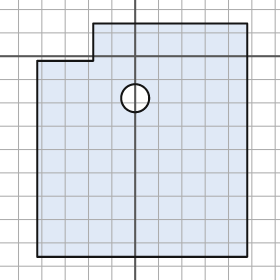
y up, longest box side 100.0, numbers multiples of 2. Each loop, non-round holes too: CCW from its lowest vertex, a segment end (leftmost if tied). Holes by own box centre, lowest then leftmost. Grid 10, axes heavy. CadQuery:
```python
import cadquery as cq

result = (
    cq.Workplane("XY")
    .moveTo(-42.0, -86.0)
    .lineTo(48.0, -86.0)
    .lineTo(48.0, 14.0)
    .lineTo(-18.0, 14.0)
    .lineTo(-18.0, -2.0)
    .lineTo(-42.0, -2.0)
    .close()
    .moveTo(0.0, -18.0)
    .circle(6.0)
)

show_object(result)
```